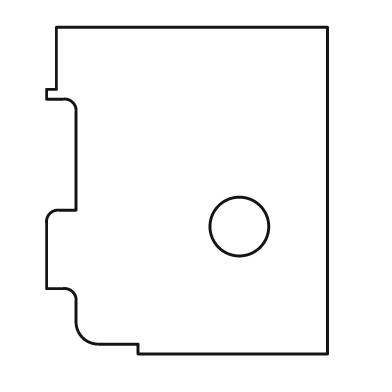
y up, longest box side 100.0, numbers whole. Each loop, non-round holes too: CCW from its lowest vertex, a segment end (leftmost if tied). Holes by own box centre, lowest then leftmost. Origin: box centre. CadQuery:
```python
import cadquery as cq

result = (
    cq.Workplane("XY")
    .moveTo(-15.0, -50.0)
    .lineTo(43.0, -50.0)
    .lineTo(43.0, 50.0)
    .lineTo(-40.0, 50.0)
    .lineTo(-40.0, 31.0)
    .lineTo(-43.0, 31.0)
    .lineTo(-43.0, 28.0)
    .lineTo(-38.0, 28.0)
    .threePointArc((-35.0, 27.0), (-34.0, 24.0))
    .lineTo(-34.0, -6.0)
    .lineTo(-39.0, -6.0)
    .threePointArc((-42.0, -7.0), (-43.0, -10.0))
    .lineTo(-43.0, -30.0)
    .lineTo(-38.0, -30.0)
    .threePointArc((-35.0, -31.0), (-34.0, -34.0))
    .lineTo(-34.0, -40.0)
    .threePointArc((-32.0, -45.0), (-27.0, -47.0))
    .lineTo(-15.0, -47.0)
    .close()
    .moveTo(16.0, -11.0)
    .circle(9.0)
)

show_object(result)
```